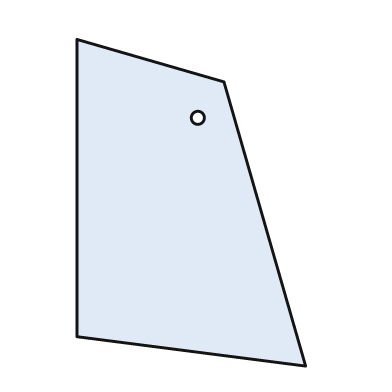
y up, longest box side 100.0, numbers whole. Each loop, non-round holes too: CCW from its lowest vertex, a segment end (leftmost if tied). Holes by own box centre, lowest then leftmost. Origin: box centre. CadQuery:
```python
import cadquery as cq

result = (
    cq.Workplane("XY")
    .moveTo(35.0, -50.0)
    .lineTo(10.0, 37.0)
    .lineTo(-35.0, 50.0)
    .lineTo(-35.0, -41.0)
    .close()
    .moveTo(2.0, 26.0)
    .circle(2.0)
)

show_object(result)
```